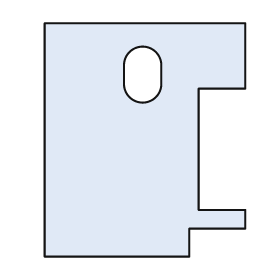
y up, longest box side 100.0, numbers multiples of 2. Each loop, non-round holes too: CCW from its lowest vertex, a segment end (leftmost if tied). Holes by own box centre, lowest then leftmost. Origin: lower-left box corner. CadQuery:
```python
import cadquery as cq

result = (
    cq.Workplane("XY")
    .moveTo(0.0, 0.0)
    .lineTo(62.0, 0.0)
    .lineTo(62.0, 12.0)
    .lineTo(86.0, 12.0)
    .lineTo(86.0, 20.0)
    .lineTo(66.0, 20.0)
    .lineTo(66.0, 72.0)
    .lineTo(86.0, 72.0)
    .lineTo(86.0, 100.0)
    .lineTo(0.0, 100.0)
    .close()
    .moveTo(34.0, 74.0)
    .threePointArc((42.0, 66.0), (50.0, 74.0))
    .lineTo(50.0, 82.0)
    .threePointArc((42.0, 90.0), (34.0, 82.0))
    .close()
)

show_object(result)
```